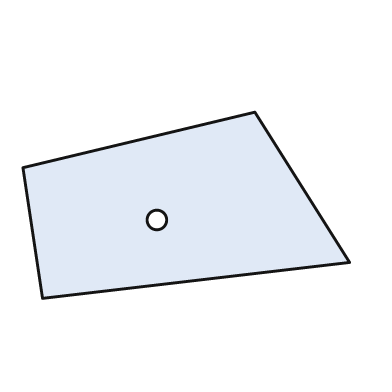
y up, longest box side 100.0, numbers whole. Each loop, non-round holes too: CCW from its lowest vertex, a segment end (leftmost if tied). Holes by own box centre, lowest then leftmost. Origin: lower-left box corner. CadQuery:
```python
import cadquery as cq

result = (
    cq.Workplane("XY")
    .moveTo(6.0, 0.0)
    .lineTo(100.0, 11.0)
    .lineTo(71.0, 57.0)
    .lineTo(0.0, 40.0)
    .close()
    .moveTo(41.0, 24.0)
    .circle(3.0)
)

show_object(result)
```